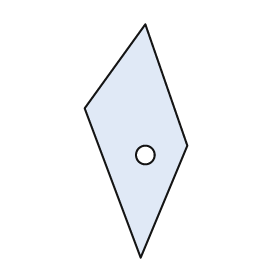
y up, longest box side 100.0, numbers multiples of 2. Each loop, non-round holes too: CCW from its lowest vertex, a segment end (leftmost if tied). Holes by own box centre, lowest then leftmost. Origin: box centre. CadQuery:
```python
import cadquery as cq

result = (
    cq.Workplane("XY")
    .moveTo(2.0, -50.0)
    .lineTo(22.0, -2.0)
    .lineTo(4.0, 50.0)
    .lineTo(-22.0, 14.0)
    .close()
    .moveTo(4.0, -6.0)
    .circle(4.0)
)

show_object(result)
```